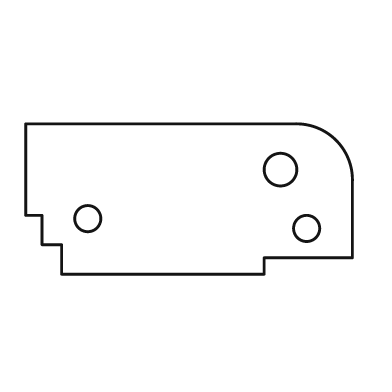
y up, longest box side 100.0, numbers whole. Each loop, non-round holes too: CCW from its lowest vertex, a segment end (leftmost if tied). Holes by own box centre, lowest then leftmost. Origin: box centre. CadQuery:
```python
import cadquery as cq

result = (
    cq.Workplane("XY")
    .moveTo(-39.0, -23.0)
    .lineTo(23.0, -23.0)
    .lineTo(23.0, -18.0)
    .lineTo(50.0, -18.0)
    .lineTo(50.0, 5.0)
    .threePointArc((45.0, 18.0), (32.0, 23.0))
    .lineTo(-50.0, 23.0)
    .lineTo(-50.0, -5.0)
    .lineTo(-45.0, -5.0)
    .lineTo(-45.0, -14.0)
    .lineTo(-39.0, -14.0)
    .close()
    .moveTo(36.0, -9.0)
    .circle(4.0)
    .moveTo(-31.0, -6.0)
    .circle(4.0)
    .moveTo(28.0, 9.0)
    .circle(5.0)
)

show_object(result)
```